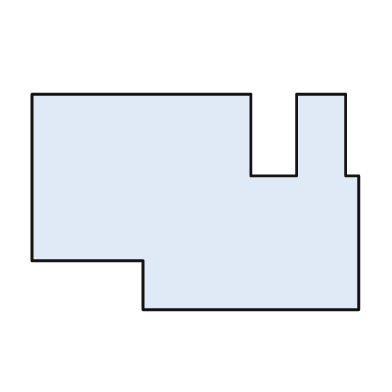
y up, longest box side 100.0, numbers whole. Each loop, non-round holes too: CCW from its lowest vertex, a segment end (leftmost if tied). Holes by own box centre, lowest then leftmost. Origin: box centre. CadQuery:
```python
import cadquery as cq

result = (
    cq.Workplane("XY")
    .moveTo(-16.0, -33.0)
    .lineTo(50.0, -33.0)
    .lineTo(50.0, 8.0)
    .lineTo(46.0, 8.0)
    .lineTo(46.0, 33.0)
    .lineTo(31.0, 33.0)
    .lineTo(31.0, 8.0)
    .lineTo(17.0, 8.0)
    .lineTo(17.0, 33.0)
    .lineTo(-50.0, 33.0)
    .lineTo(-50.0, -18.0)
    .lineTo(-16.0, -18.0)
    .close()
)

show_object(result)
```